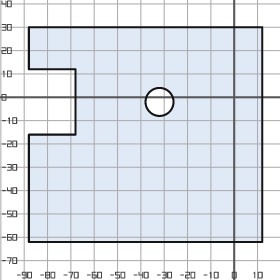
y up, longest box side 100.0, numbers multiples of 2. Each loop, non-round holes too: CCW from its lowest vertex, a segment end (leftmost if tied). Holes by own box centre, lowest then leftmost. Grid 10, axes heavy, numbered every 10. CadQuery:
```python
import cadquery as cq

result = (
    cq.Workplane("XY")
    .moveTo(-88.0, -62.0)
    .lineTo(12.0, -62.0)
    .lineTo(12.0, 30.0)
    .lineTo(-88.0, 30.0)
    .lineTo(-88.0, 12.0)
    .lineTo(-68.0, 12.0)
    .lineTo(-68.0, -16.0)
    .lineTo(-88.0, -16.0)
    .close()
    .moveTo(-32.0, -2.0)
    .circle(6.0)
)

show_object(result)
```